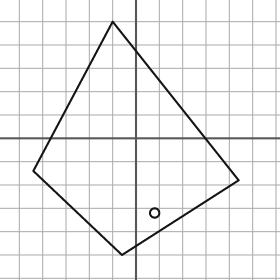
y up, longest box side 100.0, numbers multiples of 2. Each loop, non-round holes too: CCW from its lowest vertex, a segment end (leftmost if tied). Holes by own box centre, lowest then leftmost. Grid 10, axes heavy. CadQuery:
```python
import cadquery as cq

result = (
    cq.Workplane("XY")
    .moveTo(-6.0, -50.0)
    .lineTo(44.0, -18.0)
    .lineTo(-10.0, 50.0)
    .lineTo(-44.0, -14.0)
    .close()
    .moveTo(8.0, -32.0)
    .circle(2.0)
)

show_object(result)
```